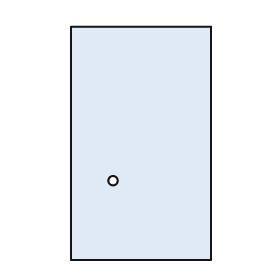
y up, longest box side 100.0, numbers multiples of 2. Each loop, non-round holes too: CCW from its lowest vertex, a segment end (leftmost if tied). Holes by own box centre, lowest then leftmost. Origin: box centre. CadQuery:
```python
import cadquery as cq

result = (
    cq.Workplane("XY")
    .moveTo(-30.0, -50.0)
    .lineTo(30.0, -50.0)
    .lineTo(30.0, 50.0)
    .lineTo(-30.0, 50.0)
    .close()
    .moveTo(-12.0, -16.0)
    .circle(2.0)
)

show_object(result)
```